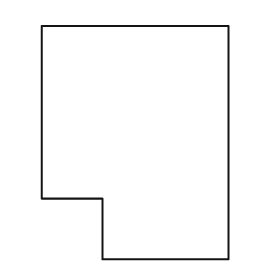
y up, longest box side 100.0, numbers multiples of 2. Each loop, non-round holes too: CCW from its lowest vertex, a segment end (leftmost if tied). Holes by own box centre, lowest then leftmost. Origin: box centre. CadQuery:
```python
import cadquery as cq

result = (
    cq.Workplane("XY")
    .moveTo(-14.0, -50.0)
    .lineTo(40.0, -50.0)
    .lineTo(40.0, 50.0)
    .lineTo(-40.0, 50.0)
    .lineTo(-40.0, -24.0)
    .lineTo(-14.0, -24.0)
    .close()
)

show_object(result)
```